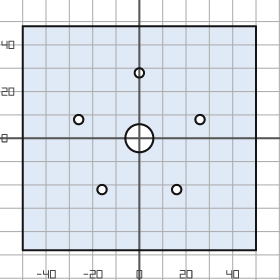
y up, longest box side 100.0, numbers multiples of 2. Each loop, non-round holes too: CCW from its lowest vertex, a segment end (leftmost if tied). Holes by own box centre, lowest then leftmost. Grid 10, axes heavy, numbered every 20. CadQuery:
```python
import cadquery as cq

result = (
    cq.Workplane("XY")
    .moveTo(-50.0, -48.0)
    .lineTo(50.0, -48.0)
    .lineTo(50.0, 48.0)
    .lineTo(-50.0, 48.0)
    .close()
    .moveTo(-16.0, -22.0)
    .circle(2.0)
    .moveTo(16.0, -22.0)
    .circle(2.0)
    .moveTo(0.0, 0.0)
    .circle(6.0)
    .moveTo(-26.0, 8.0)
    .circle(2.0)
    .moveTo(26.0, 8.0)
    .circle(2.0)
    .moveTo(0.0, 28.0)
    .circle(2.0)
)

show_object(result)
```